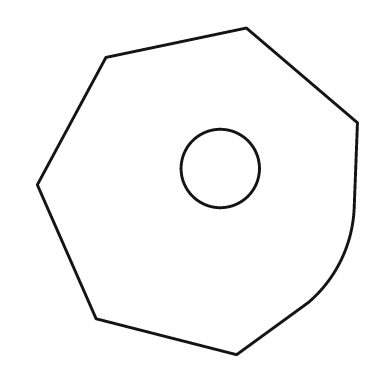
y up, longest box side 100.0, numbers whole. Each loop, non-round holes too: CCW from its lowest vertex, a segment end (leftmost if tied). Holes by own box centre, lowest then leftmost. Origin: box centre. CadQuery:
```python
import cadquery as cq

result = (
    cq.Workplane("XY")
    .moveTo(12.0, -50.0)
    .lineTo(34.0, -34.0)
    .threePointArc((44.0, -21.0), (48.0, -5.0))
    .lineTo(49.0, 21.0)
    .lineTo(15.0, 50.0)
    .lineTo(-28.0, 41.0)
    .lineTo(-49.0, 2.0)
    .lineTo(-31.0, -39.0)
    .close()
    .moveTo(7.0, 7.0)
    .circle(12.0)
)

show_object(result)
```